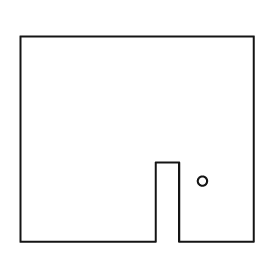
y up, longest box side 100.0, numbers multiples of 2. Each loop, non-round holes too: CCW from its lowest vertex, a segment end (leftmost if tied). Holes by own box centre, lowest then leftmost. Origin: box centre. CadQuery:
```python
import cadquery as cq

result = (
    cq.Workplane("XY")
    .moveTo(-50.0, -44.0)
    .lineTo(8.0, -44.0)
    .lineTo(8.0, -10.0)
    .lineTo(18.0, -10.0)
    .lineTo(18.0, -44.0)
    .lineTo(50.0, -44.0)
    .lineTo(50.0, 44.0)
    .lineTo(-50.0, 44.0)
    .close()
    .moveTo(28.0, -18.0)
    .circle(2.0)
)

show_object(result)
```